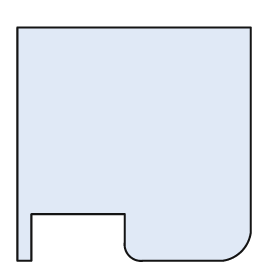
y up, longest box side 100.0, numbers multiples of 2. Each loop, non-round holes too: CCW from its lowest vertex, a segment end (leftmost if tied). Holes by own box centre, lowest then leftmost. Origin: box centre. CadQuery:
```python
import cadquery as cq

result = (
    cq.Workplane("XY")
    .moveTo(-50.0, -50.0)
    .lineTo(-44.0, -50.0)
    .lineTo(-44.0, -30.0)
    .lineTo(-4.0, -30.0)
    .lineTo(-4.0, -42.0)
    .threePointArc((-2.0, -48.0), (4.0, -50.0))
    .lineTo(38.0, -50.0)
    .threePointArc((46.0, -46.0), (50.0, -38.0))
    .lineTo(50.0, 50.0)
    .lineTo(-50.0, 50.0)
    .close()
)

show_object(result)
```